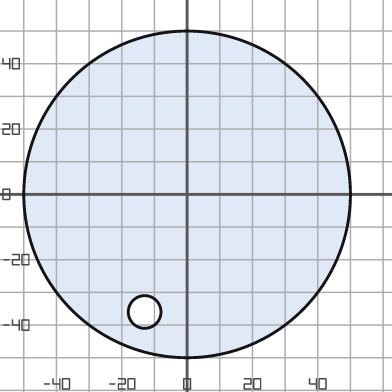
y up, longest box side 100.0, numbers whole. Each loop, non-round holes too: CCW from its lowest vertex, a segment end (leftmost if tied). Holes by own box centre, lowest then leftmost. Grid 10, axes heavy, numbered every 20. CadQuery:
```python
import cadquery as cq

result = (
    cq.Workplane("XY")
    .moveTo(0.0, 0.0)
    .circle(50.0)
    .moveTo(-13.0, -36.0)
    .circle(5.0)
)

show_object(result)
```